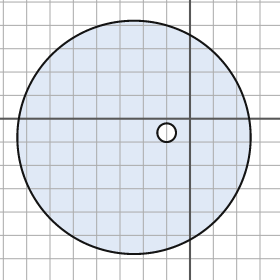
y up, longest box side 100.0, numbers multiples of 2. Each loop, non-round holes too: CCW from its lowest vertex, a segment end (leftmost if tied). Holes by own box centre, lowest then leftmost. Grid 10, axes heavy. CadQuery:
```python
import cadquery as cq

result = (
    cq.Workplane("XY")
    .moveTo(-24.0, -8.0)
    .circle(50.0)
    .moveTo(-10.0, -6.0)
    .circle(4.0)
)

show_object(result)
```